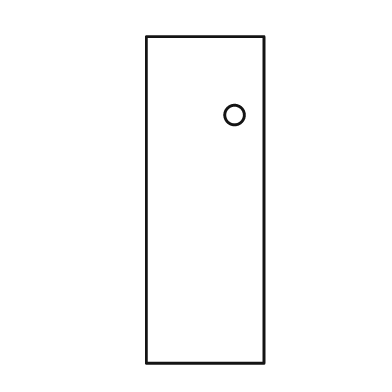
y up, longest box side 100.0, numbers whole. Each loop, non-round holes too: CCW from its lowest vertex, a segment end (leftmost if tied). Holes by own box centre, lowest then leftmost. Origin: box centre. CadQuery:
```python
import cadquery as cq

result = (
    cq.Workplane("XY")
    .moveTo(-18.0, -50.0)
    .lineTo(18.0, -50.0)
    .lineTo(18.0, 50.0)
    .lineTo(-18.0, 50.0)
    .close()
    .moveTo(9.0, 26.0)
    .circle(3.0)
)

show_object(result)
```